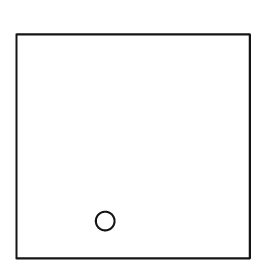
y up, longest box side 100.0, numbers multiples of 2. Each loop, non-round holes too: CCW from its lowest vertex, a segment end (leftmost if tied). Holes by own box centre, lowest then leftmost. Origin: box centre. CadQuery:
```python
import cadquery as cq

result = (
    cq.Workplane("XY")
    .moveTo(-50.0, -48.0)
    .lineTo(50.0, -48.0)
    .lineTo(50.0, 48.0)
    .lineTo(-50.0, 48.0)
    .close()
    .moveTo(-12.0, -32.0)
    .circle(4.0)
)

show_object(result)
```